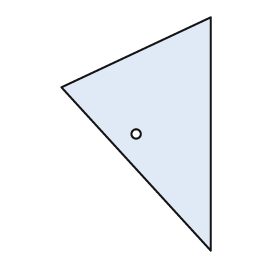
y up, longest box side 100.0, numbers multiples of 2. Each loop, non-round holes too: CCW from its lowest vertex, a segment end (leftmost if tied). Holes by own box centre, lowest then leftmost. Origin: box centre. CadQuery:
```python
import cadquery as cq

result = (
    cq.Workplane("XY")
    .moveTo(32.0, -50.0)
    .lineTo(32.0, 50.0)
    .lineTo(-32.0, 20.0)
    .close()
    .moveTo(0.0, 0.0)
    .circle(2.0)
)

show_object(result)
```